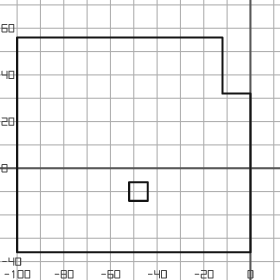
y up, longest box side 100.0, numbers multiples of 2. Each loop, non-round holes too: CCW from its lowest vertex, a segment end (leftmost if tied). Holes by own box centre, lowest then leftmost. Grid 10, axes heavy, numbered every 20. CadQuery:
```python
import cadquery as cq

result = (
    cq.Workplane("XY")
    .moveTo(-100.0, -36.0)
    .lineTo(0.0, -36.0)
    .lineTo(0.0, 32.0)
    .lineTo(-12.0, 32.0)
    .lineTo(-12.0, 56.0)
    .lineTo(-100.0, 56.0)
    .close()
    .moveTo(-52.0, -14.0)
    .lineTo(-44.0, -14.0)
    .lineTo(-44.0, -6.0)
    .lineTo(-52.0, -6.0)
    .close()
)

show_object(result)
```